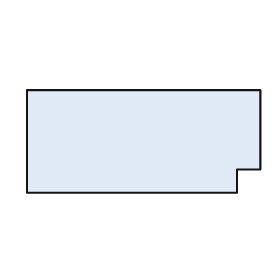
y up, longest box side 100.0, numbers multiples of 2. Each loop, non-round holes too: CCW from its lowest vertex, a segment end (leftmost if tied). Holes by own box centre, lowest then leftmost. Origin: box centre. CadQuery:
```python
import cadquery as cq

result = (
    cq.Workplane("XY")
    .moveTo(-50.0, -22.0)
    .lineTo(40.0, -22.0)
    .lineTo(40.0, -12.0)
    .lineTo(50.0, -12.0)
    .lineTo(50.0, 22.0)
    .lineTo(-50.0, 22.0)
    .close()
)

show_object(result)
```